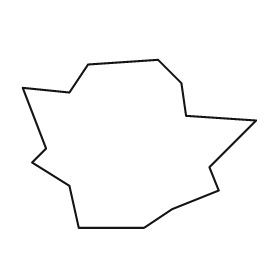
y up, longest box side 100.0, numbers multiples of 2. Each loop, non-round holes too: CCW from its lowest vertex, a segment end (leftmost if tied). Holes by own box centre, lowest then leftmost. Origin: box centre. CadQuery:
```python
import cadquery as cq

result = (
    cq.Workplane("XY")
    .moveTo(-26.0, -36.0)
    .lineTo(2.0, -36.0)
    .lineTo(14.0, -28.0)
    .lineTo(34.0, -20.0)
    .lineTo(30.0, -10.0)
    .lineTo(50.0, 10.0)
    .lineTo(20.0, 12.0)
    .lineTo(18.0, 26.0)
    .lineTo(8.0, 36.0)
    .lineTo(-22.0, 34.0)
    .lineTo(-30.0, 22.0)
    .lineTo(-50.0, 24.0)
    .lineTo(-40.0, -2.0)
    .lineTo(-46.0, -8.0)
    .lineTo(-30.0, -18.0)
    .close()
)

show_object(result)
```